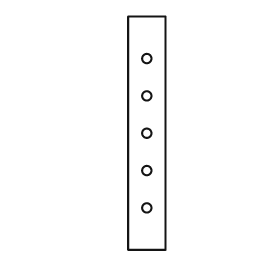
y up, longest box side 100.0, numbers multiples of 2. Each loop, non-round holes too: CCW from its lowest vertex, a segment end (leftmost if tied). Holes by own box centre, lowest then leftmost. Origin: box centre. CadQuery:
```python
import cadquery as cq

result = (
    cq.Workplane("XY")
    .moveTo(-8.0, -50.0)
    .lineTo(8.0, -50.0)
    .lineTo(8.0, 50.0)
    .lineTo(-8.0, 50.0)
    .close()
    .moveTo(0.0, -32.0)
    .circle(2.0)
    .moveTo(0.0, -16.0)
    .circle(2.0)
    .moveTo(0.0, 0.0)
    .circle(2.0)
    .moveTo(0.0, 16.0)
    .circle(2.0)
    .moveTo(0.0, 32.0)
    .circle(2.0)
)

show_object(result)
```